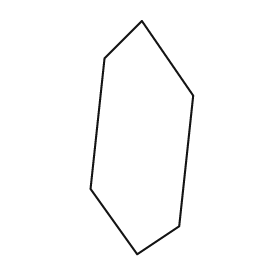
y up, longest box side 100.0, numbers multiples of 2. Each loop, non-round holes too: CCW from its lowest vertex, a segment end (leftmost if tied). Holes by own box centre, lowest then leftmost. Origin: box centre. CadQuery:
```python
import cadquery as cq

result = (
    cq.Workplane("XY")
    .moveTo(-2.0, -50.0)
    .lineTo(16.0, -38.0)
    .lineTo(22.0, 18.0)
    .lineTo(0.0, 50.0)
    .lineTo(-16.0, 34.0)
    .lineTo(-22.0, -22.0)
    .close()
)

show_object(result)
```